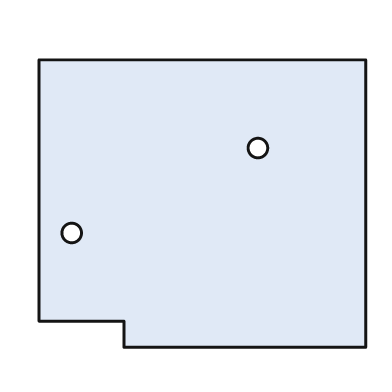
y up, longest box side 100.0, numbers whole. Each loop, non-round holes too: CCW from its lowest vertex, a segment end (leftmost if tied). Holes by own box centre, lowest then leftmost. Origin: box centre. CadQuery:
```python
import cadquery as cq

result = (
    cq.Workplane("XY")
    .moveTo(-24.0, -44.0)
    .lineTo(50.0, -44.0)
    .lineTo(50.0, 44.0)
    .lineTo(-50.0, 44.0)
    .lineTo(-50.0, -36.0)
    .lineTo(-24.0, -36.0)
    .close()
    .moveTo(-40.0, -9.0)
    .circle(3.0)
    .moveTo(17.0, 17.0)
    .circle(3.0)
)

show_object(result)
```